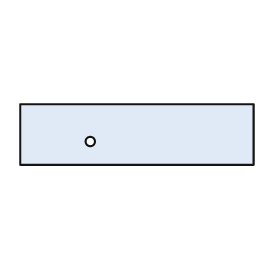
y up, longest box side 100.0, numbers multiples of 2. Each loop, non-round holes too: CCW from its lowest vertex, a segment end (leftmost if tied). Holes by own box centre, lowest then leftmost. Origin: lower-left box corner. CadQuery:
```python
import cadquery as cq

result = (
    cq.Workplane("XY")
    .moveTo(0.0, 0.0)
    .lineTo(100.0, 0.0)
    .lineTo(100.0, 26.0)
    .lineTo(0.0, 26.0)
    .close()
    .moveTo(30.0, 10.0)
    .circle(2.0)
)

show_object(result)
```